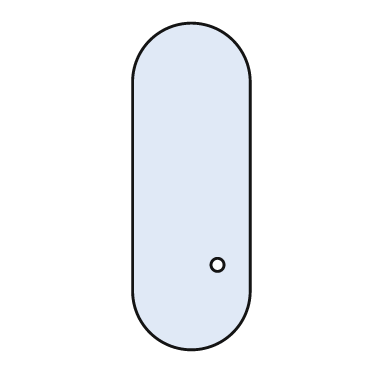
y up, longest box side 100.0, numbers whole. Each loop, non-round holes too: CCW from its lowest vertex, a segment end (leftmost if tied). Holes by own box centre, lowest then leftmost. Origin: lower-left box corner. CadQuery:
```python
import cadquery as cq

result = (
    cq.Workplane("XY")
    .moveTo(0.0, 18.0)
    .threePointArc((18.0, 0.0), (36.0, 18.0))
    .lineTo(36.0, 82.0)
    .threePointArc((18.0, 100.0), (0.0, 82.0))
    .close()
    .moveTo(26.0, 26.0)
    .circle(2.0)
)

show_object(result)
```